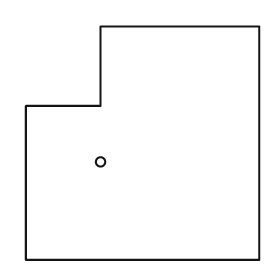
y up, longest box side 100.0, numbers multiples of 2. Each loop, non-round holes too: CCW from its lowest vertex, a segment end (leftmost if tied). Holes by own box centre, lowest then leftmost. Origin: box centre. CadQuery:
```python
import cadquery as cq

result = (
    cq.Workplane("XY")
    .moveTo(-50.0, -50.0)
    .lineTo(50.0, -50.0)
    .lineTo(50.0, 50.0)
    .lineTo(-18.0, 50.0)
    .lineTo(-18.0, 16.0)
    .lineTo(-50.0, 16.0)
    .close()
    .moveTo(-18.0, -8.0)
    .circle(2.0)
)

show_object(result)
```